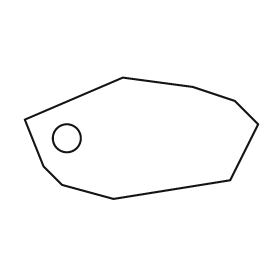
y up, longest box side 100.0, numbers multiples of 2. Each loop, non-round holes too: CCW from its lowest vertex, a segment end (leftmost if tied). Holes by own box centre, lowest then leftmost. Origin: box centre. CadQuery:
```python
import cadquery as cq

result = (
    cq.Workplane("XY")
    .moveTo(-12.0, -26.0)
    .lineTo(38.0, -18.0)
    .lineTo(50.0, 6.0)
    .lineTo(40.0, 16.0)
    .lineTo(22.0, 22.0)
    .lineTo(-8.0, 26.0)
    .lineTo(-50.0, 8.0)
    .lineTo(-42.0, -12.0)
    .lineTo(-34.0, -20.0)
    .close()
    .moveTo(-32.0, 0.0)
    .circle(6.0)
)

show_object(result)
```